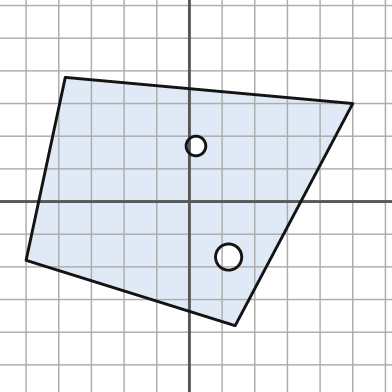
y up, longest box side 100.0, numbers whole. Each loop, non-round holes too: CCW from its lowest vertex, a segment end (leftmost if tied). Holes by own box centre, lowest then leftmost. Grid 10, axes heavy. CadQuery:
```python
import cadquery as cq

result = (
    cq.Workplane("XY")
    .moveTo(14.0, -38.0)
    .lineTo(50.0, 30.0)
    .lineTo(-38.0, 38.0)
    .lineTo(-50.0, -18.0)
    .close()
    .moveTo(12.0, -17.0)
    .circle(4.0)
    .moveTo(2.0, 17.0)
    .circle(3.0)
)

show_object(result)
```